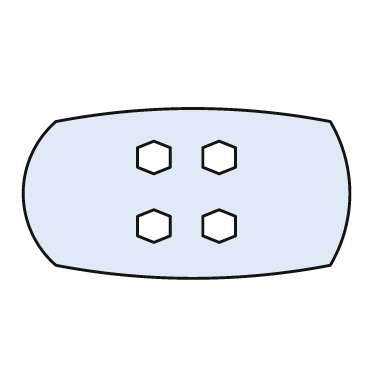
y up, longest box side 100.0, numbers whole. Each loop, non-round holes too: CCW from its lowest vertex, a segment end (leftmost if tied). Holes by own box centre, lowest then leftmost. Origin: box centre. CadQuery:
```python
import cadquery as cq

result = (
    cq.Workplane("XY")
    .moveTo(-40.0, -22.0)
    .threePointArc((2.0, -26.0), (44.0, -22.0))
    .threePointArc((50.0, 0.0), (44.0, 22.0))
    .threePointArc((2.0, 26.0), (-40.0, 22.0))
    .threePointArc((-50.0, 0.0), (-40.0, -22.0))
    .close()
    .moveTo(-10.0, -15.0)
    .lineTo(-5.0, -13.0)
    .lineTo(-5.0, -7.0)
    .lineTo(-10.0, -5.0)
    .lineTo(-15.0, -7.0)
    .lineTo(-15.0, -13.0)
    .close()
    .moveTo(10.0, -15.0)
    .lineTo(15.0, -13.0)
    .lineTo(15.0, -7.0)
    .lineTo(10.0, -5.0)
    .lineTo(5.0, -7.0)
    .lineTo(5.0, -13.0)
    .close()
    .moveTo(-10.0, 6.0)
    .lineTo(-5.0, 8.0)
    .lineTo(-5.0, 14.0)
    .lineTo(-10.0, 16.0)
    .lineTo(-15.0, 14.0)
    .lineTo(-15.0, 8.0)
    .close()
    .moveTo(10.0, 6.0)
    .lineTo(15.0, 8.0)
    .lineTo(15.0, 14.0)
    .lineTo(10.0, 16.0)
    .lineTo(5.0, 14.0)
    .lineTo(5.0, 8.0)
    .close()
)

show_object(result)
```